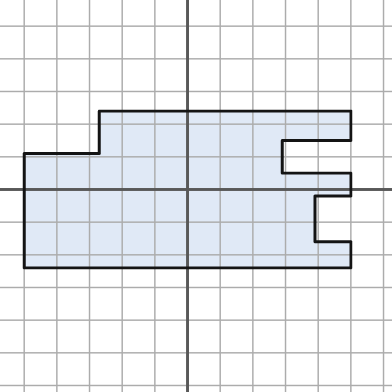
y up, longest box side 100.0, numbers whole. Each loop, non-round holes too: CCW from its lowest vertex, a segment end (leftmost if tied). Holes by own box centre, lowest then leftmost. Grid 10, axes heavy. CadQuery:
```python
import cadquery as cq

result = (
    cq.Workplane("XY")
    .moveTo(-50.0, -24.0)
    .lineTo(50.0, -24.0)
    .lineTo(50.0, -16.0)
    .lineTo(39.0, -16.0)
    .lineTo(39.0, -2.0)
    .lineTo(50.0, -2.0)
    .lineTo(50.0, 5.0)
    .lineTo(29.0, 5.0)
    .lineTo(29.0, 15.0)
    .lineTo(50.0, 15.0)
    .lineTo(50.0, 24.0)
    .lineTo(-27.0, 24.0)
    .lineTo(-27.0, 11.0)
    .lineTo(-50.0, 11.0)
    .close()
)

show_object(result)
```